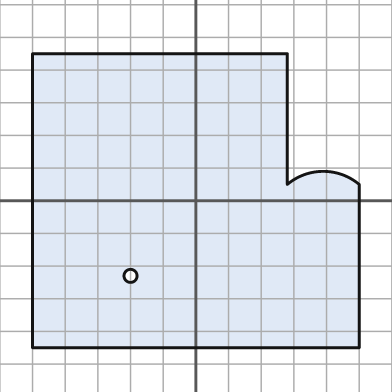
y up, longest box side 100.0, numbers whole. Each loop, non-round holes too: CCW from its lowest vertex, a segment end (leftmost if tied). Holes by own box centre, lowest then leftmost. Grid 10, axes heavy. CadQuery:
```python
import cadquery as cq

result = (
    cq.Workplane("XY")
    .moveTo(-50.0, -45.0)
    .lineTo(50.0, -45.0)
    .lineTo(50.0, 5.0)
    .threePointArc((39.0, 9.0), (28.0, 5.0))
    .lineTo(28.0, 45.0)
    .lineTo(-50.0, 45.0)
    .close()
    .moveTo(-20.0, -23.0)
    .circle(2.0)
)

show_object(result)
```